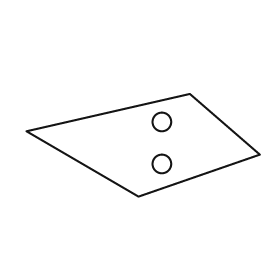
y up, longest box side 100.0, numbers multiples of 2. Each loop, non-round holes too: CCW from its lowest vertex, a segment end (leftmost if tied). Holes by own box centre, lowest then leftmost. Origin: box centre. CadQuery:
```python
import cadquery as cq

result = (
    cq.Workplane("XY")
    .moveTo(-2.0, -22.0)
    .lineTo(50.0, -4.0)
    .lineTo(20.0, 22.0)
    .lineTo(-50.0, 6.0)
    .close()
    .moveTo(8.0, -8.0)
    .circle(4.0)
    .moveTo(8.0, 10.0)
    .circle(4.0)
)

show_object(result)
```